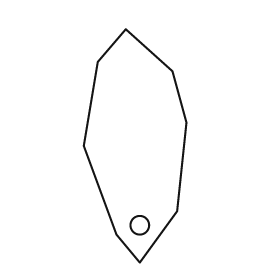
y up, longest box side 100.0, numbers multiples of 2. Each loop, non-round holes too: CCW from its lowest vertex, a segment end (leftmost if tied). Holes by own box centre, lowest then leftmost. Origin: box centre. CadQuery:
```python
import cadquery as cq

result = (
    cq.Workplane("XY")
    .moveTo(2.0, -50.0)
    .lineTo(18.0, -28.0)
    .lineTo(22.0, 10.0)
    .lineTo(16.0, 32.0)
    .lineTo(-4.0, 50.0)
    .lineTo(-16.0, 36.0)
    .lineTo(-22.0, 0.0)
    .lineTo(-8.0, -38.0)
    .close()
    .moveTo(2.0, -34.0)
    .circle(4.0)
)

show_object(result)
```